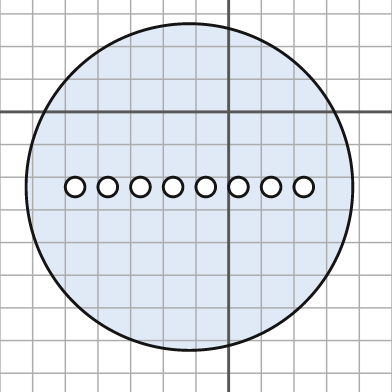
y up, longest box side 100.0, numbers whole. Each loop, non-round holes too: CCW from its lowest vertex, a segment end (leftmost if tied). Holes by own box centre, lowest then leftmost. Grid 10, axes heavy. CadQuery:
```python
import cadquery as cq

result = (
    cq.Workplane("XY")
    .moveTo(-12.0, -23.0)
    .circle(50.0)
    .moveTo(-47.0, -23.0)
    .circle(3.0)
    .moveTo(-37.0, -23.0)
    .circle(3.0)
    .moveTo(-27.0, -23.0)
    .circle(3.0)
    .moveTo(-17.0, -23.0)
    .circle(3.0)
    .moveTo(-7.0, -23.0)
    .circle(3.0)
    .moveTo(3.0, -23.0)
    .circle(3.0)
    .moveTo(13.0, -23.0)
    .circle(3.0)
    .moveTo(23.0, -23.0)
    .circle(3.0)
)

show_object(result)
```